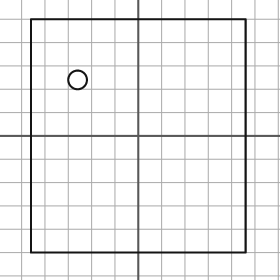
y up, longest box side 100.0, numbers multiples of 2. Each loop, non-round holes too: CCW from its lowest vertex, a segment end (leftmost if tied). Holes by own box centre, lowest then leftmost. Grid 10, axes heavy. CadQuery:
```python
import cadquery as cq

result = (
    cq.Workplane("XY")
    .moveTo(-46.0, -50.0)
    .lineTo(46.0, -50.0)
    .lineTo(46.0, 50.0)
    .lineTo(-46.0, 50.0)
    .close()
    .moveTo(-26.0, 24.0)
    .circle(4.0)
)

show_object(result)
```